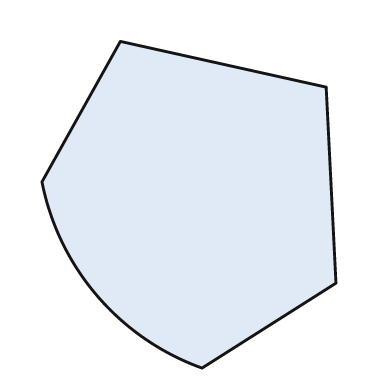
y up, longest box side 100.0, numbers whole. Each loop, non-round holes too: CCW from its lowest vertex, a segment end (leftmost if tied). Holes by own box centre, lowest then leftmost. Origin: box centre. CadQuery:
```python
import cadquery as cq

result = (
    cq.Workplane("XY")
    .moveTo(4.0, -50.0)
    .lineTo(45.0, -24.0)
    .lineTo(42.0, 36.0)
    .lineTo(-21.0, 50.0)
    .lineTo(-45.0, 7.0)
    .threePointArc((-28.0, -28.0), (4.0, -50.0))
    .close()
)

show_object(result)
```